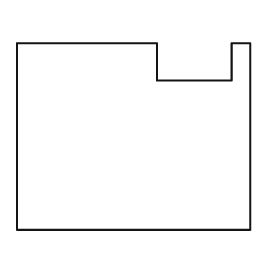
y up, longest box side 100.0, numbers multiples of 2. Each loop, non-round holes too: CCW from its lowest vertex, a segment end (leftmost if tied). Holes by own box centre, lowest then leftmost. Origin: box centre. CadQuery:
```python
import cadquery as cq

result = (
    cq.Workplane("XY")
    .moveTo(-50.0, -40.0)
    .lineTo(50.0, -40.0)
    .lineTo(50.0, 40.0)
    .lineTo(42.0, 40.0)
    .lineTo(42.0, 24.0)
    .lineTo(10.0, 24.0)
    .lineTo(10.0, 40.0)
    .lineTo(-50.0, 40.0)
    .close()
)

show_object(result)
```